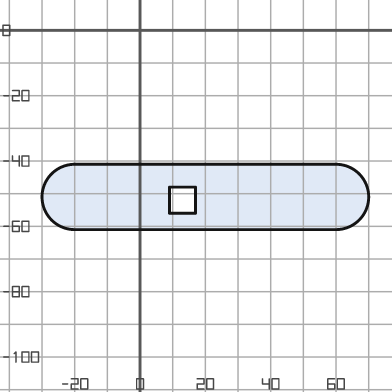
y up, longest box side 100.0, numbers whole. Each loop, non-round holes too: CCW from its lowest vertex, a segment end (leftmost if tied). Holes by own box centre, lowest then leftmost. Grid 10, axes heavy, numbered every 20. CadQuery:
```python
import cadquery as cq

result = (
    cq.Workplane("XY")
    .moveTo(-20.0, -61.0)
    .lineTo(60.0, -61.0)
    .threePointArc((70.0, -51.0), (60.0, -41.0))
    .lineTo(-20.0, -41.0)
    .threePointArc((-30.0, -51.0), (-20.0, -61.0))
    .close()
    .moveTo(9.0, -56.0)
    .lineTo(17.0, -56.0)
    .lineTo(17.0, -48.0)
    .lineTo(9.0, -48.0)
    .close()
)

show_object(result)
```